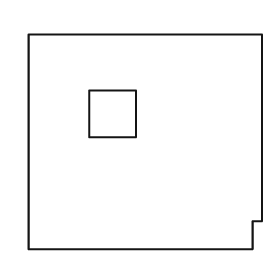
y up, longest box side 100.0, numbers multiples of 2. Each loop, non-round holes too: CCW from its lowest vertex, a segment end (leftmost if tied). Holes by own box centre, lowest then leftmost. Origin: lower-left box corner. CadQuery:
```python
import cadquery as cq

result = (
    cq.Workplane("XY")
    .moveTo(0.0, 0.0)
    .lineTo(96.0, 0.0)
    .lineTo(96.0, 12.0)
    .lineTo(100.0, 12.0)
    .lineTo(100.0, 92.0)
    .lineTo(0.0, 92.0)
    .close()
    .moveTo(26.0, 48.0)
    .lineTo(46.0, 48.0)
    .lineTo(46.0, 68.0)
    .lineTo(26.0, 68.0)
    .close()
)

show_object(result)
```